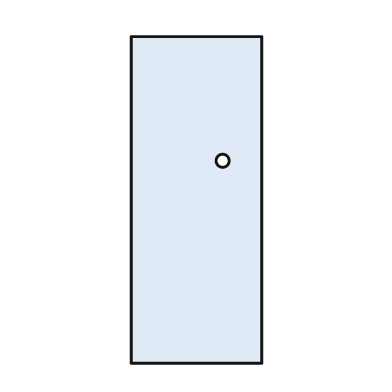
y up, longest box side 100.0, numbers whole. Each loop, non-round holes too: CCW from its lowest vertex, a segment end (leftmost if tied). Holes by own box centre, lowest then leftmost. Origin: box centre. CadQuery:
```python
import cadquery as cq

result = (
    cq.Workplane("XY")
    .moveTo(-20.0, -50.0)
    .lineTo(20.0, -50.0)
    .lineTo(20.0, 50.0)
    .lineTo(-20.0, 50.0)
    .close()
    .moveTo(8.0, 12.0)
    .circle(2.0)
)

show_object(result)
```